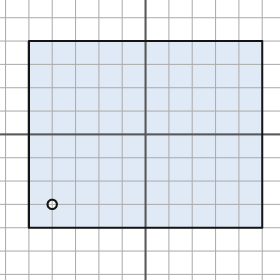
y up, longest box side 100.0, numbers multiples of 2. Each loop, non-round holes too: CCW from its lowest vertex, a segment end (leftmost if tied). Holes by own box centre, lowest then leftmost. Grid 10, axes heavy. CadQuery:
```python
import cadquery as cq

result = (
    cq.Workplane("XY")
    .moveTo(-50.0, -40.0)
    .lineTo(50.0, -40.0)
    .lineTo(50.0, 40.0)
    .lineTo(-50.0, 40.0)
    .close()
    .moveTo(-40.0, -30.0)
    .circle(2.0)
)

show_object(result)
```